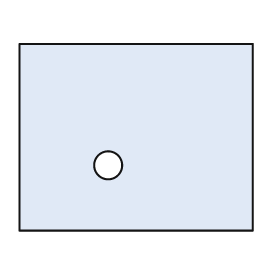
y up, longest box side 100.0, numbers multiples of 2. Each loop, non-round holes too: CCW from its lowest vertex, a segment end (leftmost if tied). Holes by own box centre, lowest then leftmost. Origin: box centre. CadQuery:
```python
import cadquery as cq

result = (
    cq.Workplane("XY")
    .moveTo(-50.0, -40.0)
    .lineTo(50.0, -40.0)
    .lineTo(50.0, 40.0)
    .lineTo(-50.0, 40.0)
    .close()
    .moveTo(-12.0, -12.0)
    .circle(6.0)
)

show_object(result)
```